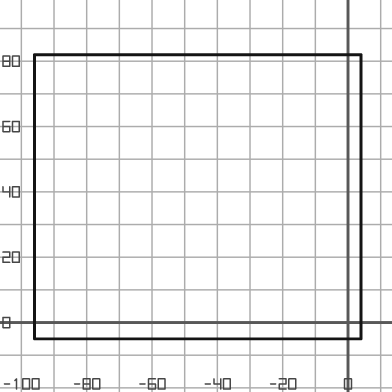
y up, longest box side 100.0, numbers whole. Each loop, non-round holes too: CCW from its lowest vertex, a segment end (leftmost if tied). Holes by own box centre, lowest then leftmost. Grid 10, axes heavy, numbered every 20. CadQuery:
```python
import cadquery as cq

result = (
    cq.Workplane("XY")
    .moveTo(-96.0, -5.0)
    .lineTo(4.0, -5.0)
    .lineTo(4.0, 82.0)
    .lineTo(-96.0, 82.0)
    .close()
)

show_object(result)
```